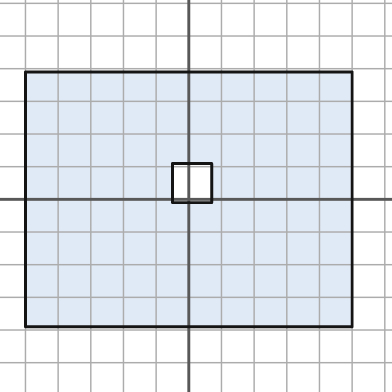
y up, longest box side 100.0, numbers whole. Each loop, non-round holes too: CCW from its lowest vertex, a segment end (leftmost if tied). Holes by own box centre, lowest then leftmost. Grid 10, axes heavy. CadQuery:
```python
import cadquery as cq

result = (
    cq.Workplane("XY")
    .moveTo(-50.0, -39.0)
    .lineTo(50.0, -39.0)
    .lineTo(50.0, 39.0)
    .lineTo(-50.0, 39.0)
    .close()
    .moveTo(-5.0, -1.0)
    .lineTo(7.0, -1.0)
    .lineTo(7.0, 11.0)
    .lineTo(-5.0, 11.0)
    .close()
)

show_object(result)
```